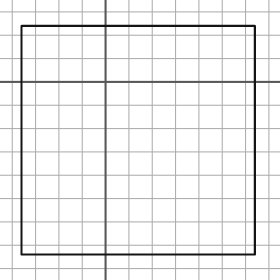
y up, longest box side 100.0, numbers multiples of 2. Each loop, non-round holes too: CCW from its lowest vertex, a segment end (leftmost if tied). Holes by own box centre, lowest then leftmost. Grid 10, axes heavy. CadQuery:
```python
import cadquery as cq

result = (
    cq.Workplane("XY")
    .moveTo(-36.0, -74.0)
    .lineTo(64.0, -74.0)
    .lineTo(64.0, 24.0)
    .lineTo(-36.0, 24.0)
    .close()
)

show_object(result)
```